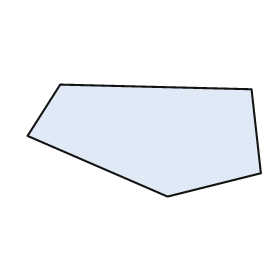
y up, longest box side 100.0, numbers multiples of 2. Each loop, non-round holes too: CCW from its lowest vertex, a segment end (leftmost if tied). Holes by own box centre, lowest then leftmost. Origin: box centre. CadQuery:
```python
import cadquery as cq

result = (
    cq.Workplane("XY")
    .moveTo(10.0, -24.0)
    .lineTo(50.0, -14.0)
    .lineTo(46.0, 22.0)
    .lineTo(-36.0, 24.0)
    .lineTo(-50.0, 2.0)
    .close()
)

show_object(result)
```